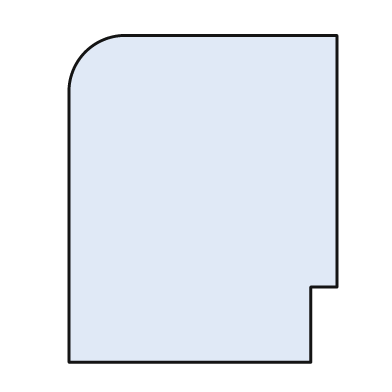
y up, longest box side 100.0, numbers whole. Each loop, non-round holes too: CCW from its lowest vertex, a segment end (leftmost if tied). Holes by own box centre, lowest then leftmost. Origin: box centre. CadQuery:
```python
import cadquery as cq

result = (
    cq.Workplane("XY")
    .moveTo(-41.0, -50.0)
    .lineTo(33.0, -50.0)
    .lineTo(33.0, -27.0)
    .lineTo(41.0, -27.0)
    .lineTo(41.0, 50.0)
    .lineTo(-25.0, 50.0)
    .threePointArc((-36.0, 45.0), (-41.0, 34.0))
    .close()
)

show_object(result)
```